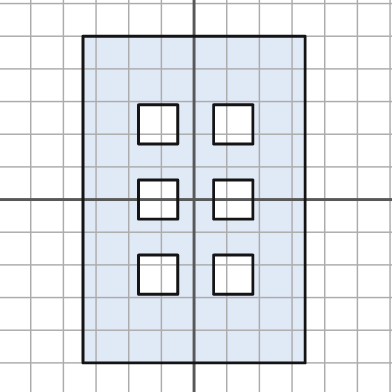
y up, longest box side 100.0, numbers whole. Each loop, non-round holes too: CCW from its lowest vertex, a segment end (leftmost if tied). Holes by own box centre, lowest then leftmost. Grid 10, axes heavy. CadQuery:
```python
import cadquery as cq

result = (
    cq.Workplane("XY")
    .moveTo(-34.0, -50.0)
    .lineTo(34.0, -50.0)
    .lineTo(34.0, 50.0)
    .lineTo(-34.0, 50.0)
    .close()
    .moveTo(-17.0, -29.0)
    .lineTo(-5.0, -29.0)
    .lineTo(-5.0, -17.0)
    .lineTo(-17.0, -17.0)
    .close()
    .moveTo(6.0, -29.0)
    .lineTo(18.0, -29.0)
    .lineTo(18.0, -17.0)
    .lineTo(6.0, -17.0)
    .close()
    .moveTo(-17.0, -6.0)
    .lineTo(-5.0, -6.0)
    .lineTo(-5.0, 6.0)
    .lineTo(-17.0, 6.0)
    .close()
    .moveTo(6.0, -6.0)
    .lineTo(18.0, -6.0)
    .lineTo(18.0, 6.0)
    .lineTo(6.0, 6.0)
    .close()
    .moveTo(-17.0, 17.0)
    .lineTo(-5.0, 17.0)
    .lineTo(-5.0, 29.0)
    .lineTo(-17.0, 29.0)
    .close()
    .moveTo(6.0, 17.0)
    .lineTo(18.0, 17.0)
    .lineTo(18.0, 29.0)
    .lineTo(6.0, 29.0)
    .close()
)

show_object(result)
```